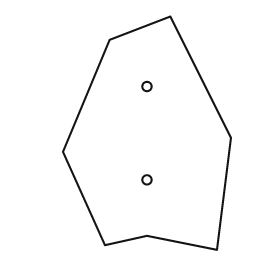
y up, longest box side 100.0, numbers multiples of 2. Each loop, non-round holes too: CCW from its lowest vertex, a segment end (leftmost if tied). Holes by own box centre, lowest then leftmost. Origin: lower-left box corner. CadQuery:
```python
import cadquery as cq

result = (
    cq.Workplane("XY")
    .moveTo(66.0, 0.0)
    .lineTo(72.0, 48.0)
    .lineTo(46.0, 100.0)
    .lineTo(20.0, 90.0)
    .lineTo(0.0, 42.0)
    .lineTo(18.0, 2.0)
    .lineTo(36.0, 6.0)
    .close()
    .moveTo(36.0, 30.0)
    .circle(2.0)
    .moveTo(36.0, 70.0)
    .circle(2.0)
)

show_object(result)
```